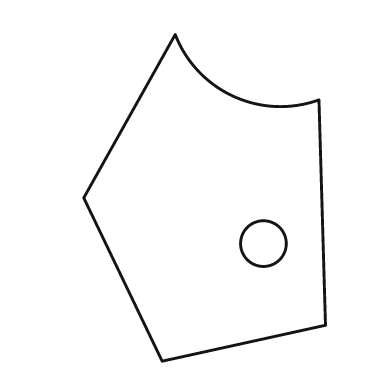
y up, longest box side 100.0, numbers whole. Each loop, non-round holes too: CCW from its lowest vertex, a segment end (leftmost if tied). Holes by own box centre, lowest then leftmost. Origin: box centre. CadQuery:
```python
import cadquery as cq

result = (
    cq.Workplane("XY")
    .moveTo(-13.0, -50.0)
    .lineTo(37.0, -39.0)
    .lineTo(35.0, 30.0)
    .threePointArc((9.0, 31.0), (-9.0, 50.0))
    .lineTo(-37.0, 0.0)
    .close()
    .moveTo(18.0, -14.0)
    .circle(7.0)
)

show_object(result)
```